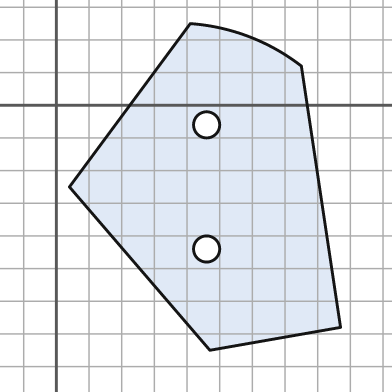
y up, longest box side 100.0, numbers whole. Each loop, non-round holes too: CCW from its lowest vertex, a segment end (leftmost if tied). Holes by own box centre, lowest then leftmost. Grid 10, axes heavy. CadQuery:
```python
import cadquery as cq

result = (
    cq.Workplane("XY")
    .moveTo(47.0, -75.0)
    .lineTo(87.0, -68.0)
    .lineTo(75.0, 12.0)
    .threePointArc((59.0, 21.0), (41.0, 25.0))
    .lineTo(4.0, -25.0)
    .close()
    .moveTo(46.0, -44.0)
    .circle(4.0)
    .moveTo(46.0, -6.0)
    .circle(4.0)
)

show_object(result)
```